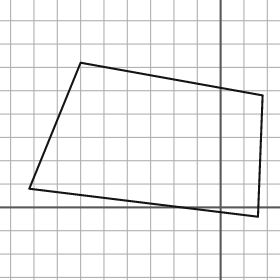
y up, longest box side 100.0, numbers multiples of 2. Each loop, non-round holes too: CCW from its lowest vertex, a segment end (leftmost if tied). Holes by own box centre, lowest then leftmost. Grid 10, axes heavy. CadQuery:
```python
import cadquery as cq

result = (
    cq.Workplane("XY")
    .moveTo(16.0, -4.0)
    .lineTo(18.0, 48.0)
    .lineTo(-60.0, 62.0)
    .lineTo(-82.0, 8.0)
    .close()
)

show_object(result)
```